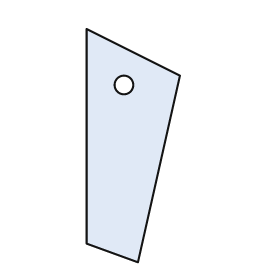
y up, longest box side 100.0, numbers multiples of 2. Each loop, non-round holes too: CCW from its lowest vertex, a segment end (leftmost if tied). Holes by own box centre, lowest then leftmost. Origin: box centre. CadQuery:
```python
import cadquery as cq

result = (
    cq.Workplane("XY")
    .moveTo(2.0, -50.0)
    .lineTo(20.0, 30.0)
    .lineTo(-20.0, 50.0)
    .lineTo(-20.0, -42.0)
    .close()
    .moveTo(-4.0, 26.0)
    .circle(4.0)
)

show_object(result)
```